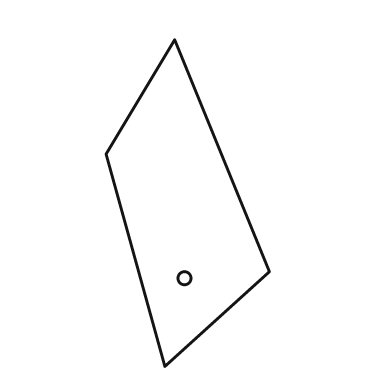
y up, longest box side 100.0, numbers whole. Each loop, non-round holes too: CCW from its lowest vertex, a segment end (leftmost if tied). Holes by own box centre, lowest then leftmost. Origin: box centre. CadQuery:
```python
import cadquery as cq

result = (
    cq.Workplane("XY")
    .moveTo(-7.0, -50.0)
    .lineTo(25.0, -21.0)
    .lineTo(-4.0, 50.0)
    .lineTo(-25.0, 15.0)
    .close()
    .moveTo(-1.0, -23.0)
    .circle(2.0)
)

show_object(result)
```